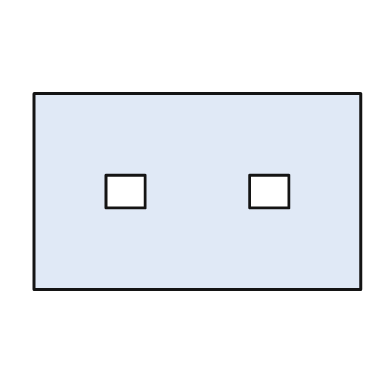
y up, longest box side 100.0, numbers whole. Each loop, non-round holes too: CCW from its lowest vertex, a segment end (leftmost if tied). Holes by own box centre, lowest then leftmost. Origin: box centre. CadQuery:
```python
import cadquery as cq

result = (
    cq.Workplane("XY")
    .moveTo(-50.0, -30.0)
    .lineTo(50.0, -30.0)
    .lineTo(50.0, 30.0)
    .lineTo(-50.0, 30.0)
    .close()
    .moveTo(-28.0, -5.0)
    .lineTo(-16.0, -5.0)
    .lineTo(-16.0, 5.0)
    .lineTo(-28.0, 5.0)
    .close()
    .moveTo(16.0, -5.0)
    .lineTo(28.0, -5.0)
    .lineTo(28.0, 5.0)
    .lineTo(16.0, 5.0)
    .close()
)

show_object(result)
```